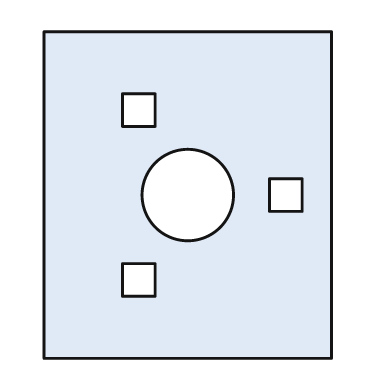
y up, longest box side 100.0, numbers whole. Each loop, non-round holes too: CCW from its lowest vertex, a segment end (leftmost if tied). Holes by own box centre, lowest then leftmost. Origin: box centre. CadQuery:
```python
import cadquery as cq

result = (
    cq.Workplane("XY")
    .moveTo(-44.0, -50.0)
    .lineTo(44.0, -50.0)
    .lineTo(44.0, 50.0)
    .lineTo(-44.0, 50.0)
    .close()
    .moveTo(-20.0, -31.0)
    .lineTo(-10.0, -31.0)
    .lineTo(-10.0, -21.0)
    .lineTo(-20.0, -21.0)
    .close()
    .moveTo(0.0, 0.0)
    .circle(14.0)
    .moveTo(25.0, -5.0)
    .lineTo(35.0, -5.0)
    .lineTo(35.0, 5.0)
    .lineTo(25.0, 5.0)
    .close()
    .moveTo(-20.0, 21.0)
    .lineTo(-10.0, 21.0)
    .lineTo(-10.0, 31.0)
    .lineTo(-20.0, 31.0)
    .close()
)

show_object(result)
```